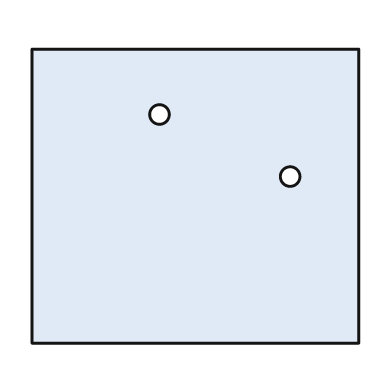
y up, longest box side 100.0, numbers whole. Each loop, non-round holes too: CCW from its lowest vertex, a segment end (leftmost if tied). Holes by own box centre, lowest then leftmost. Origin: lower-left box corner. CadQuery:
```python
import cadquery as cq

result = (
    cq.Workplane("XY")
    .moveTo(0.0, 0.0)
    .lineTo(100.0, 0.0)
    .lineTo(100.0, 90.0)
    .lineTo(0.0, 90.0)
    .close()
    .moveTo(79.0, 51.0)
    .circle(3.0)
    .moveTo(39.0, 70.0)
    .circle(3.0)
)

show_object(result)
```